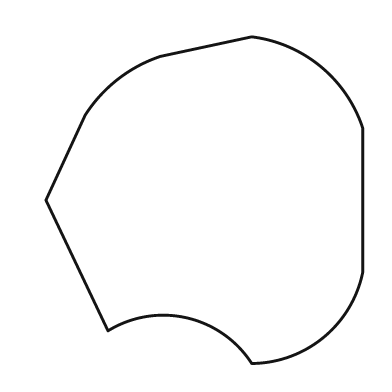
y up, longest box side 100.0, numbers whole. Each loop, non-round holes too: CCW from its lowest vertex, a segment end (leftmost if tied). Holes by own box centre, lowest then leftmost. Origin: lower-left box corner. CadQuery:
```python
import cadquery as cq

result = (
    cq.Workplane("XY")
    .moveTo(63.0, 0.0)
    .threePointArc((85.0, 8.0), (97.0, 28.0))
    .lineTo(97.0, 72.0)
    .threePointArc((84.0, 91.0), (63.0, 100.0))
    .lineTo(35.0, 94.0)
    .threePointArc((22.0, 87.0), (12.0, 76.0))
    .lineTo(0.0, 50.0)
    .lineTo(19.0, 10.0)
    .threePointArc((43.0, 14.0), (63.0, 0.0))
    .close()
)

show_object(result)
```